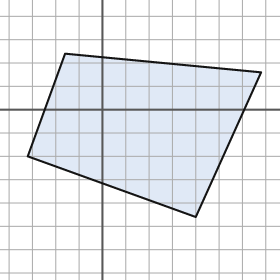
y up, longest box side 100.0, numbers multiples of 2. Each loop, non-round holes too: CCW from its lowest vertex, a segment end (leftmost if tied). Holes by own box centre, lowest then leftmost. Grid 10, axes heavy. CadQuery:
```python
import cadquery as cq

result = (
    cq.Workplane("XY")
    .moveTo(40.0, -46.0)
    .lineTo(68.0, 16.0)
    .lineTo(-16.0, 24.0)
    .lineTo(-32.0, -20.0)
    .close()
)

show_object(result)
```